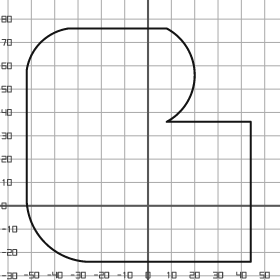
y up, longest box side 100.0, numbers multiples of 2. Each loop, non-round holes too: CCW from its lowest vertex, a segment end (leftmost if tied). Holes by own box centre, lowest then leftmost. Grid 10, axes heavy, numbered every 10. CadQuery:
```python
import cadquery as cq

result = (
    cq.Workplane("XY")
    .moveTo(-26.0, -24.0)
    .lineTo(44.0, -24.0)
    .lineTo(44.0, 36.0)
    .lineTo(8.0, 36.0)
    .threePointArc((20.0, 56.0), (8.0, 76.0))
    .lineTo(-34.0, 76.0)
    .threePointArc((-46.0, 70.0), (-52.0, 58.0))
    .lineTo(-52.0, 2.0)
    .threePointArc((-44.0, -16.0), (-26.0, -24.0))
    .close()
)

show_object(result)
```